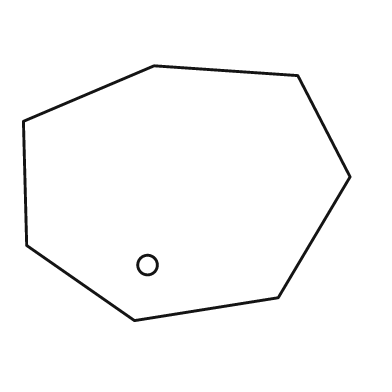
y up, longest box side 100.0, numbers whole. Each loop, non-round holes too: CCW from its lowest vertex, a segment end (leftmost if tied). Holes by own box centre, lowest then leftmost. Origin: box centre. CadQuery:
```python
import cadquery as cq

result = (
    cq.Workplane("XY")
    .moveTo(-16.0, -39.0)
    .lineTo(28.0, -32.0)
    .lineTo(50.0, 5.0)
    .lineTo(34.0, 36.0)
    .lineTo(-10.0, 39.0)
    .lineTo(-50.0, 22.0)
    .lineTo(-49.0, -16.0)
    .close()
    .moveTo(-12.0, -22.0)
    .circle(3.0)
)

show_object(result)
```